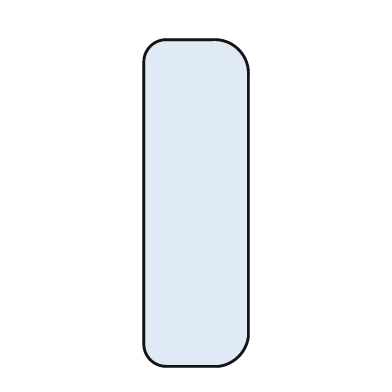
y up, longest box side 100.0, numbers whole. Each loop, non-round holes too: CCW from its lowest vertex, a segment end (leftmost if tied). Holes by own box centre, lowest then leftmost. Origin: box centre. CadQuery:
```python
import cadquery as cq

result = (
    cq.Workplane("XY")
    .moveTo(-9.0, -50.0)
    .lineTo(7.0, -50.0)
    .threePointArc((13.0, -47.0), (16.0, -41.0))
    .lineTo(16.0, 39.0)
    .threePointArc((13.0, 47.0), (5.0, 50.0))
    .lineTo(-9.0, 50.0)
    .threePointArc((-14.0, 48.0), (-16.0, 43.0))
    .lineTo(-16.0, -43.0)
    .threePointArc((-14.0, -48.0), (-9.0, -50.0))
    .close()
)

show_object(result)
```